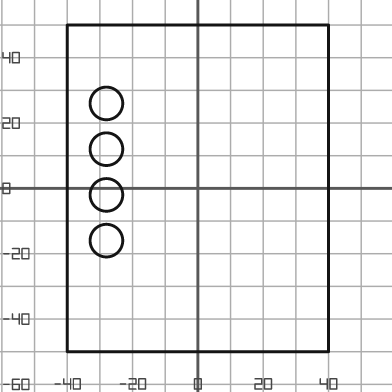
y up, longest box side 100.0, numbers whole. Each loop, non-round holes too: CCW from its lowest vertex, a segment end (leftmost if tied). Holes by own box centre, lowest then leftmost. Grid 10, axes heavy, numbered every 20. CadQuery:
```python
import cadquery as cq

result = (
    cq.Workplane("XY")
    .moveTo(-40.0, -50.0)
    .lineTo(40.0, -50.0)
    .lineTo(40.0, 50.0)
    .lineTo(-40.0, 50.0)
    .close()
    .moveTo(-28.0, -16.0)
    .circle(5.0)
    .moveTo(-28.0, -2.0)
    .circle(5.0)
    .moveTo(-28.0, 12.0)
    .circle(5.0)
    .moveTo(-28.0, 26.0)
    .circle(5.0)
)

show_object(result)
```